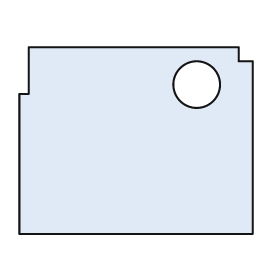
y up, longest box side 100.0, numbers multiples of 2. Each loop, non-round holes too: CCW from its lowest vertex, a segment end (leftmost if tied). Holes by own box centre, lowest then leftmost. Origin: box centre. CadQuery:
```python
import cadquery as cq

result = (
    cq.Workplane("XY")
    .moveTo(-50.0, -40.0)
    .lineTo(50.0, -40.0)
    .lineTo(50.0, 34.0)
    .lineTo(44.0, 34.0)
    .lineTo(44.0, 40.0)
    .lineTo(-46.0, 40.0)
    .lineTo(-46.0, 20.0)
    .lineTo(-50.0, 20.0)
    .close()
    .moveTo(26.0, 24.0)
    .circle(10.0)
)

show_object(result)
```